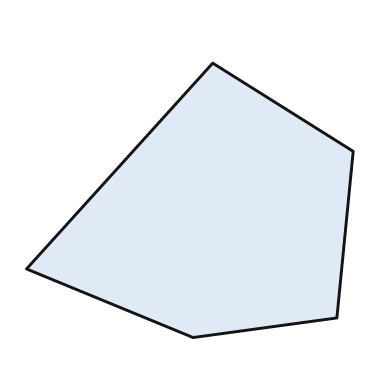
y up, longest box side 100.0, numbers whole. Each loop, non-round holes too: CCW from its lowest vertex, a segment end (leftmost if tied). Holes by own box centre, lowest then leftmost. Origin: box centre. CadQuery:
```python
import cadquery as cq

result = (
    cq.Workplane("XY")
    .moveTo(1.0, -42.0)
    .lineTo(45.0, -36.0)
    .lineTo(50.0, 15.0)
    .lineTo(7.0, 42.0)
    .lineTo(-50.0, -21.0)
    .close()
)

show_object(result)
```